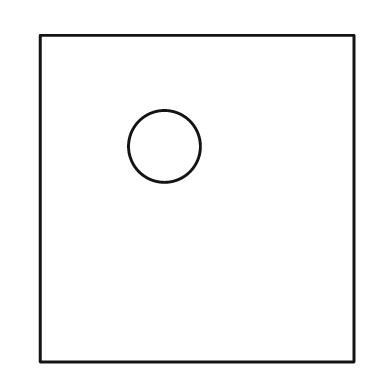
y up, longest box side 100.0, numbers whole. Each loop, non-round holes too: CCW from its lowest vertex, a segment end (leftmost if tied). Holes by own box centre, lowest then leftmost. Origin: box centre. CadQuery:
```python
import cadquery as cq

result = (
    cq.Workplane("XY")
    .moveTo(-48.0, -50.0)
    .lineTo(48.0, -50.0)
    .lineTo(48.0, 50.0)
    .lineTo(-48.0, 50.0)
    .close()
    .moveTo(-10.0, 16.0)
    .circle(11.0)
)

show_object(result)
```